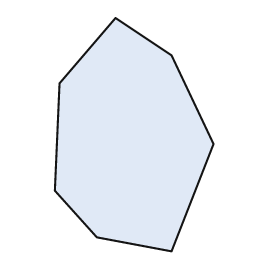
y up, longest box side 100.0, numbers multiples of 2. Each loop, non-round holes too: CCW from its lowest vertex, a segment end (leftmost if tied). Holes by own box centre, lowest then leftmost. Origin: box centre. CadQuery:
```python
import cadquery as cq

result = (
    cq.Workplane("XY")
    .moveTo(16.0, -50.0)
    .lineTo(34.0, -4.0)
    .lineTo(16.0, 34.0)
    .lineTo(-8.0, 50.0)
    .lineTo(-32.0, 22.0)
    .lineTo(-34.0, -24.0)
    .lineTo(-16.0, -44.0)
    .close()
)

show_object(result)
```